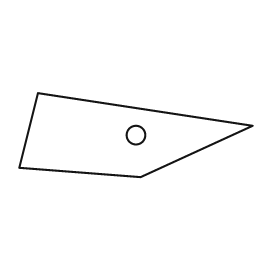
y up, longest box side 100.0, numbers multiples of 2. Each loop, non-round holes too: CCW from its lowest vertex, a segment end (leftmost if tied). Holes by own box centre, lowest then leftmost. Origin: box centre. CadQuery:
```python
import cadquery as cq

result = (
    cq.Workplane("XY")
    .moveTo(2.0, -18.0)
    .lineTo(50.0, 4.0)
    .lineTo(-42.0, 18.0)
    .lineTo(-50.0, -14.0)
    .close()
    .moveTo(0.0, 0.0)
    .circle(4.0)
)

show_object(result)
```